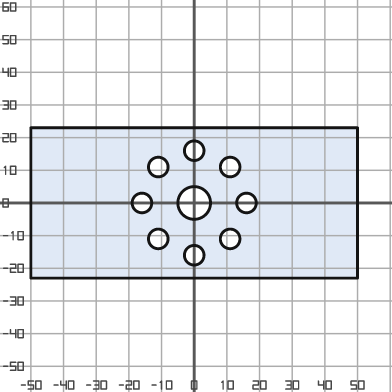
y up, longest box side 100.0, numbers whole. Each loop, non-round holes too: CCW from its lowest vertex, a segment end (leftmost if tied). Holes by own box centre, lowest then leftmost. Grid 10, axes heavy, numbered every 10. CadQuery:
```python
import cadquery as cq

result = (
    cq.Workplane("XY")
    .moveTo(-50.0, -23.0)
    .lineTo(50.0, -23.0)
    .lineTo(50.0, 23.0)
    .lineTo(-50.0, 23.0)
    .close()
    .moveTo(0.0, -16.0)
    .circle(3.0)
    .moveTo(-11.0, -11.0)
    .circle(3.0)
    .moveTo(11.0, -11.0)
    .circle(3.0)
    .moveTo(-16.0, 0.0)
    .circle(3.0)
    .moveTo(0.0, 0.0)
    .circle(5.0)
    .moveTo(16.0, 0.0)
    .circle(3.0)
    .moveTo(-11.0, 11.0)
    .circle(3.0)
    .moveTo(11.0, 11.0)
    .circle(3.0)
    .moveTo(0.0, 16.0)
    .circle(3.0)
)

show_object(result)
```